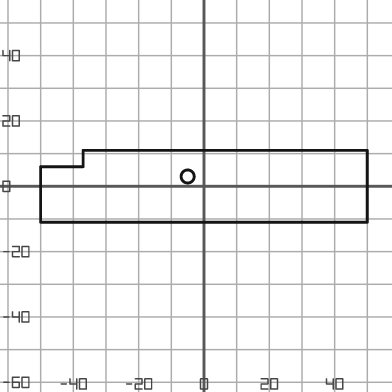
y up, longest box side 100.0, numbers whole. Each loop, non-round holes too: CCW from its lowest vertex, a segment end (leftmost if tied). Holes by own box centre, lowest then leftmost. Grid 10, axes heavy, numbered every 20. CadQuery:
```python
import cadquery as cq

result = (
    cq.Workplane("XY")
    .moveTo(-50.0, -11.0)
    .lineTo(50.0, -11.0)
    .lineTo(50.0, 11.0)
    .lineTo(-37.0, 11.0)
    .lineTo(-37.0, 6.0)
    .lineTo(-50.0, 6.0)
    .close()
    .moveTo(-5.0, 3.0)
    .circle(2.0)
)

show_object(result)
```